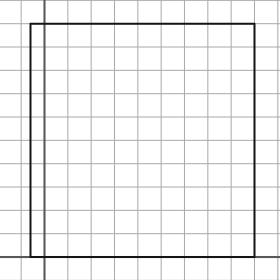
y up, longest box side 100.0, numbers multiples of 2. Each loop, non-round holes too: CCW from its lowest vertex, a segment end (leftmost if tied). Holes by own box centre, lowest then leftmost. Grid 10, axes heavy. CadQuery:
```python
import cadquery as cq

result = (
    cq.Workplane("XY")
    .moveTo(-6.0, 0.0)
    .lineTo(90.0, 0.0)
    .lineTo(90.0, 100.0)
    .lineTo(-6.0, 100.0)
    .close()
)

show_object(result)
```